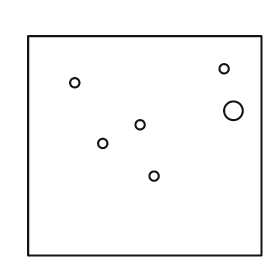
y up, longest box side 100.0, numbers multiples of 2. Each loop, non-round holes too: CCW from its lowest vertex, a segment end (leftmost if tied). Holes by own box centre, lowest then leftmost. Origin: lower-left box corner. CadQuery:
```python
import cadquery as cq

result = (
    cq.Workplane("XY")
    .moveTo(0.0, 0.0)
    .lineTo(100.0, 0.0)
    .lineTo(100.0, 94.0)
    .lineTo(0.0, 94.0)
    .close()
    .moveTo(54.0, 34.0)
    .circle(2.0)
    .moveTo(32.0, 48.0)
    .circle(2.0)
    .moveTo(48.0, 56.0)
    .circle(2.0)
    .moveTo(88.0, 62.0)
    .circle(4.0)
    .moveTo(20.0, 74.0)
    .circle(2.0)
    .moveTo(84.0, 80.0)
    .circle(2.0)
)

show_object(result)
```